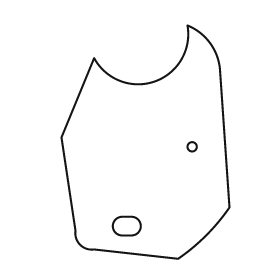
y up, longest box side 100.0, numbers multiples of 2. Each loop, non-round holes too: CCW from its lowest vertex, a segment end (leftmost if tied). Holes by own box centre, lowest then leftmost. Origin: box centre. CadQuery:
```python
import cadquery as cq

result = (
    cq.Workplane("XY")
    .moveTo(14.0, -50.0)
    .threePointArc((26.0, -40.0), (36.0, -28.0))
    .lineTo(32.0, 30.0)
    .threePointArc((28.0, 42.0), (18.0, 50.0))
    .threePointArc((4.0, 26.0), (-22.0, 36.0))
    .lineTo(-36.0, 2.0)
    .lineTo(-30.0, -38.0)
    .threePointArc((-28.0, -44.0), (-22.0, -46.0))
    .close()
    .moveTo(-10.0, -40.0)
    .lineTo(-6.0, -40.0)
    .threePointArc((-2.0, -36.0), (-6.0, -32.0))
    .lineTo(-10.0, -32.0)
    .threePointArc((-14.0, -36.0), (-10.0, -40.0))
    .close()
    .moveTo(20.0, -2.0)
    .circle(2.0)
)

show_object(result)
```